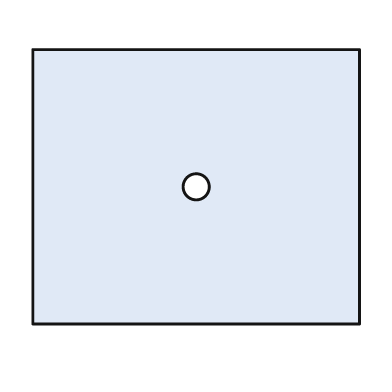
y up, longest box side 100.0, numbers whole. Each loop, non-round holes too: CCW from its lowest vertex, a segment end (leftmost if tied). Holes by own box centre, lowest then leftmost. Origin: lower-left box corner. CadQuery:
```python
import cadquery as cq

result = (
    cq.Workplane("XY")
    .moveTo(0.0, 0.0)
    .lineTo(100.0, 0.0)
    .lineTo(100.0, 84.0)
    .lineTo(0.0, 84.0)
    .close()
    .moveTo(50.0, 42.0)
    .circle(4.0)
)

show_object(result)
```